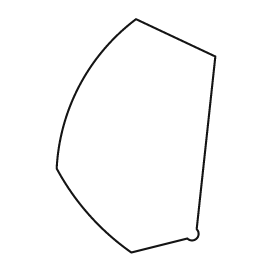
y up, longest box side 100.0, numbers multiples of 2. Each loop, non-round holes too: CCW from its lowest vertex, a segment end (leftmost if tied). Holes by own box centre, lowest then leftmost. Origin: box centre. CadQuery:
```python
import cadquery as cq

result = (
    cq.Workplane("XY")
    .moveTo(-2.0, -50.0)
    .lineTo(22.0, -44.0)
    .threePointArc((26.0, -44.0), (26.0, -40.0))
    .lineTo(34.0, 34.0)
    .lineTo(0.0, 50.0)
    .threePointArc((-24.0, 22.0), (-34.0, -14.0))
    .threePointArc((-20.0, -34.0), (-2.0, -50.0))
    .close()
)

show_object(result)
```